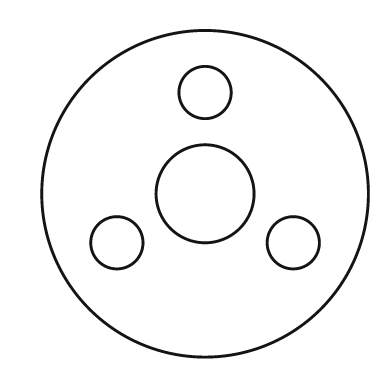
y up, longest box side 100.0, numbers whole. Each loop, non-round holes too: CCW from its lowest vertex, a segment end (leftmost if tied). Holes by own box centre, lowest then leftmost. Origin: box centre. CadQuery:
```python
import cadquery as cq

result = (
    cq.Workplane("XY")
    .moveTo(0.0, 0.0)
    .circle(50.0)
    .moveTo(-27.0, -15.0)
    .circle(8.0)
    .moveTo(27.0, -15.0)
    .circle(8.0)
    .moveTo(0.0, 0.0)
    .circle(15.0)
    .moveTo(0.0, 31.0)
    .circle(8.0)
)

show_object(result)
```